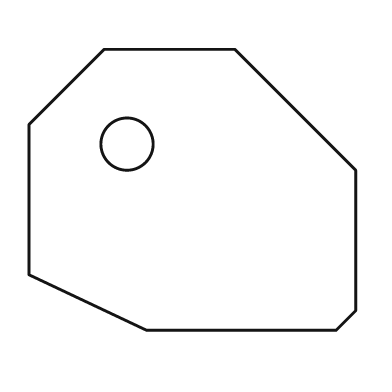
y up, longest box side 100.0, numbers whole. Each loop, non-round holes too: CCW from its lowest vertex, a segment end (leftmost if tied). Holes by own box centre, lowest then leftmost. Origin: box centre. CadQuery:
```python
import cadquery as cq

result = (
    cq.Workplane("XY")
    .moveTo(-14.0, -43.0)
    .lineTo(44.0, -43.0)
    .lineTo(50.0, -37.0)
    .lineTo(50.0, 6.0)
    .lineTo(13.0, 43.0)
    .lineTo(-27.0, 43.0)
    .lineTo(-50.0, 20.0)
    .lineTo(-50.0, -26.0)
    .close()
    .moveTo(-20.0, 14.0)
    .circle(8.0)
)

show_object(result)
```